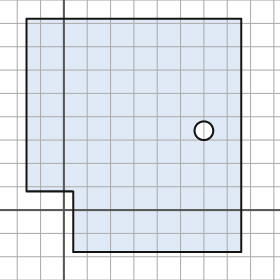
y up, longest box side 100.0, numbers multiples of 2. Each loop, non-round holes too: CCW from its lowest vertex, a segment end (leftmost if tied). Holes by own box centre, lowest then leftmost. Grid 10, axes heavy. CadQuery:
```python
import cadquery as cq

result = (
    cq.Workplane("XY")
    .moveTo(4.0, -18.0)
    .lineTo(76.0, -18.0)
    .lineTo(76.0, 82.0)
    .lineTo(-16.0, 82.0)
    .lineTo(-16.0, 8.0)
    .lineTo(4.0, 8.0)
    .close()
    .moveTo(60.0, 34.0)
    .circle(4.0)
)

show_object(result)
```